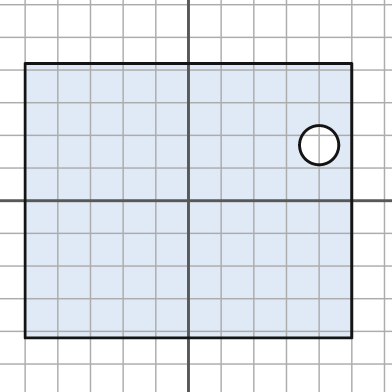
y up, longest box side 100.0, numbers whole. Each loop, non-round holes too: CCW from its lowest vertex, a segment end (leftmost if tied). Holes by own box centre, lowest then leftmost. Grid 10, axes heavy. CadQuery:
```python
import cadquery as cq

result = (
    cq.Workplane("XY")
    .moveTo(-50.0, -42.0)
    .lineTo(50.0, -42.0)
    .lineTo(50.0, 42.0)
    .lineTo(-50.0, 42.0)
    .close()
    .moveTo(40.0, 17.0)
    .circle(6.0)
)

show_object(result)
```